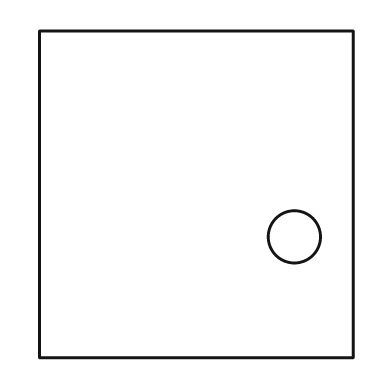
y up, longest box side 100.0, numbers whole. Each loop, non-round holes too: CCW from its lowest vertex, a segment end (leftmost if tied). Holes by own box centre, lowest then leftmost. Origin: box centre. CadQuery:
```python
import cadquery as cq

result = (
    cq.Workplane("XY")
    .moveTo(-48.0, -50.0)
    .lineTo(48.0, -50.0)
    .lineTo(48.0, 50.0)
    .lineTo(-48.0, 50.0)
    .close()
    .moveTo(30.0, -13.0)
    .circle(8.0)
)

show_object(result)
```